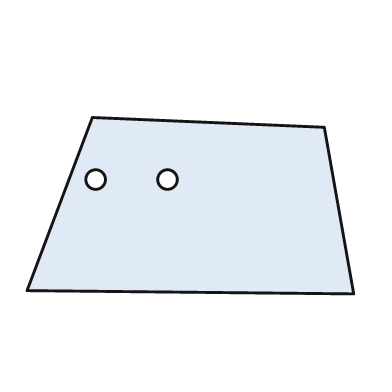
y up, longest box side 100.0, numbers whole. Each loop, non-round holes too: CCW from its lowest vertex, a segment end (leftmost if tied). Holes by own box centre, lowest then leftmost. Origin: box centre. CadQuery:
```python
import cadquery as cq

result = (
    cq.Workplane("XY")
    .moveTo(50.0, -27.0)
    .lineTo(41.0, 24.0)
    .lineTo(-30.0, 27.0)
    .lineTo(-50.0, -26.0)
    .close()
    .moveTo(-29.0, 8.0)
    .circle(3.0)
    .moveTo(-7.0, 8.0)
    .circle(3.0)
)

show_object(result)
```